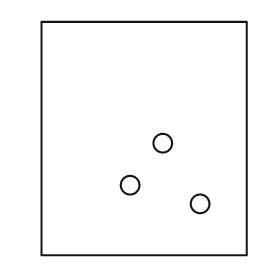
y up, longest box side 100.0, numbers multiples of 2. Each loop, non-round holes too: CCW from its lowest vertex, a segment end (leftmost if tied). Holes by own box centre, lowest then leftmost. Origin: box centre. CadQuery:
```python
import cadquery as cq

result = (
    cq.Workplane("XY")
    .moveTo(-44.0, -50.0)
    .lineTo(44.0, -50.0)
    .lineTo(44.0, 50.0)
    .lineTo(-44.0, 50.0)
    .close()
    .moveTo(24.0, -28.0)
    .circle(4.0)
    .moveTo(-6.0, -20.0)
    .circle(4.0)
    .moveTo(8.0, -2.0)
    .circle(4.0)
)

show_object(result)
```